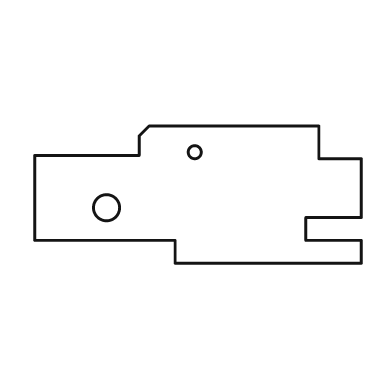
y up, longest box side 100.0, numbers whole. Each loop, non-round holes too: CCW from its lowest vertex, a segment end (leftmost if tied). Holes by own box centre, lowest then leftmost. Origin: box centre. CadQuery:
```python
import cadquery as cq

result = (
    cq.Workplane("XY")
    .moveTo(-7.0, -21.0)
    .lineTo(50.0, -21.0)
    .lineTo(50.0, -14.0)
    .lineTo(33.0, -14.0)
    .lineTo(33.0, -7.0)
    .lineTo(50.0, -7.0)
    .lineTo(50.0, 11.0)
    .lineTo(37.0, 11.0)
    .lineTo(37.0, 21.0)
    .lineTo(-15.0, 21.0)
    .lineTo(-18.0, 18.0)
    .lineTo(-18.0, 12.0)
    .lineTo(-50.0, 12.0)
    .lineTo(-50.0, -14.0)
    .lineTo(-7.0, -14.0)
    .close()
    .moveTo(-28.0, -4.0)
    .circle(4.0)
    .moveTo(-1.0, 13.0)
    .circle(2.0)
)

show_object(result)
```